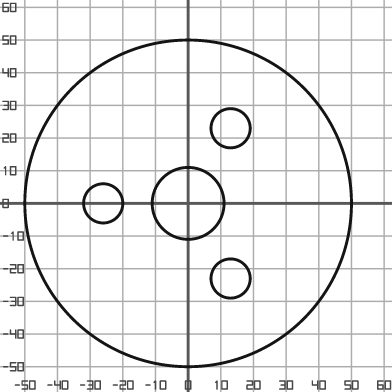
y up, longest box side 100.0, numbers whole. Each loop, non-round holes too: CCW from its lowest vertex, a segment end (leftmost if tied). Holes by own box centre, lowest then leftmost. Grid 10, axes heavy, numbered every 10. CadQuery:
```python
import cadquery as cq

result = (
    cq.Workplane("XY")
    .moveTo(0.0, 0.0)
    .circle(50.0)
    .moveTo(13.0, -23.0)
    .circle(6.0)
    .moveTo(-26.0, 0.0)
    .circle(6.0)
    .moveTo(0.0, 0.0)
    .circle(11.0)
    .moveTo(13.0, 23.0)
    .circle(6.0)
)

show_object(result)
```